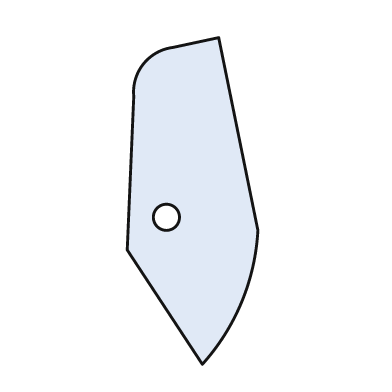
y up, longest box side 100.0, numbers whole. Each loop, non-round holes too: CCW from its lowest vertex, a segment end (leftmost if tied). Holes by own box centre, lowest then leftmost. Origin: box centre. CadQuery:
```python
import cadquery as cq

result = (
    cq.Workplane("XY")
    .moveTo(3.0, -50.0)
    .threePointArc((15.0, -31.0), (20.0, -9.0))
    .lineTo(8.0, 50.0)
    .lineTo(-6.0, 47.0)
    .threePointArc((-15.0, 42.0), (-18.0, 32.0))
    .lineTo(-20.0, -15.0)
    .close()
    .moveTo(-8.0, -5.0)
    .circle(4.0)
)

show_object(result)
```